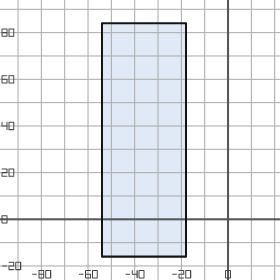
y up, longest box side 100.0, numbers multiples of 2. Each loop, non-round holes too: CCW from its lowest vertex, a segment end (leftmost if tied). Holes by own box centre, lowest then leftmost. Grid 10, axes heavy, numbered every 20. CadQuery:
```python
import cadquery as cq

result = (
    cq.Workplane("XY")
    .moveTo(-54.0, -16.0)
    .lineTo(-18.0, -16.0)
    .lineTo(-18.0, 84.0)
    .lineTo(-54.0, 84.0)
    .close()
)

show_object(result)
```